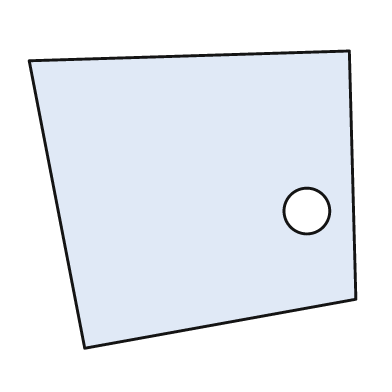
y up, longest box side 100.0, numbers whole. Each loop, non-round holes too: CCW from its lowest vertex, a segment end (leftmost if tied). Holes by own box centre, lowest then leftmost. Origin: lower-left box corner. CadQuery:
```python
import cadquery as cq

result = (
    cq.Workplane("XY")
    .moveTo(17.0, 0.0)
    .lineTo(100.0, 15.0)
    .lineTo(98.0, 91.0)
    .lineTo(0.0, 88.0)
    .close()
    .moveTo(85.0, 42.0)
    .circle(7.0)
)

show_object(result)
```